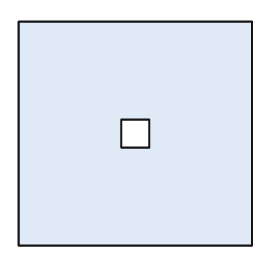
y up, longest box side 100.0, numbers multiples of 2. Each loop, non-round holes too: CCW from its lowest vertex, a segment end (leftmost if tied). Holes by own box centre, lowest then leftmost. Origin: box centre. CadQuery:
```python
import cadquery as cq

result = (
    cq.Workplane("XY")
    .moveTo(-50.0, -48.0)
    .lineTo(50.0, -48.0)
    .lineTo(50.0, 48.0)
    .lineTo(-50.0, 48.0)
    .close()
    .moveTo(-6.0, -6.0)
    .lineTo(6.0, -6.0)
    .lineTo(6.0, 6.0)
    .lineTo(-6.0, 6.0)
    .close()
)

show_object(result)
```